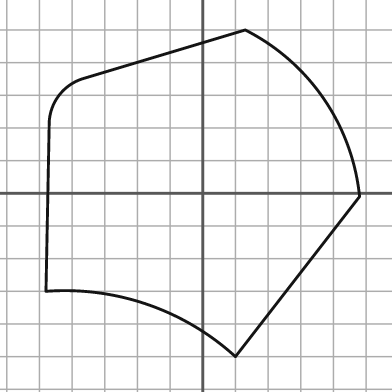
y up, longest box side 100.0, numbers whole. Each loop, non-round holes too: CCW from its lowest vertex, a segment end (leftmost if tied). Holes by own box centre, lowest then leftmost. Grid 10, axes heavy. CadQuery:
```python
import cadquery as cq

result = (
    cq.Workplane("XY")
    .moveTo(10.0, -50.0)
    .lineTo(48.0, -1.0)
    .threePointArc((37.0, 29.0), (13.0, 50.0))
    .lineTo(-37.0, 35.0)
    .threePointArc((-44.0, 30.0), (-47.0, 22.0))
    .lineTo(-48.0, -30.0)
    .threePointArc((-17.0, -34.0), (10.0, -50.0))
    .close()
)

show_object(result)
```